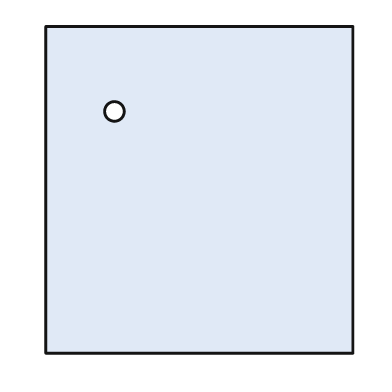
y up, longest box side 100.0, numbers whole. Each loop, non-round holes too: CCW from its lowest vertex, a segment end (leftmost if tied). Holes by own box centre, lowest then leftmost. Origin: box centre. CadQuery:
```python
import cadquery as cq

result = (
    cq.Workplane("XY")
    .moveTo(-47.0, -50.0)
    .lineTo(47.0, -50.0)
    .lineTo(47.0, 50.0)
    .lineTo(-47.0, 50.0)
    .close()
    .moveTo(-26.0, 24.0)
    .circle(3.0)
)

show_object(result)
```